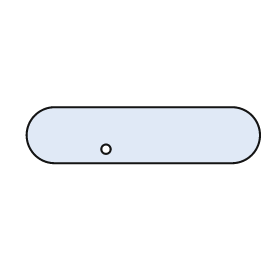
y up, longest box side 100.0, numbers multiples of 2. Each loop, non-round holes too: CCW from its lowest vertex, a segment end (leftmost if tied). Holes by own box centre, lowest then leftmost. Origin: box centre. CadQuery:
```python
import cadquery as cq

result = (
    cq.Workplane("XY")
    .moveTo(-38.0, -12.0)
    .lineTo(38.0, -12.0)
    .threePointArc((50.0, 0.0), (38.0, 12.0))
    .lineTo(-38.0, 12.0)
    .threePointArc((-50.0, 0.0), (-38.0, -12.0))
    .close()
    .moveTo(-16.0, -6.0)
    .circle(2.0)
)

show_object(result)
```